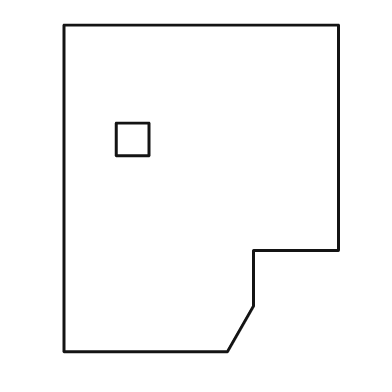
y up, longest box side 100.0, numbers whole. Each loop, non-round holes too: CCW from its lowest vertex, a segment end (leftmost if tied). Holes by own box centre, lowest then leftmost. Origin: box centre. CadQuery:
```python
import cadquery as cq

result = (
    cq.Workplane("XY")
    .moveTo(-42.0, -50.0)
    .lineTo(8.0, -50.0)
    .lineTo(16.0, -36.0)
    .lineTo(16.0, -19.0)
    .lineTo(42.0, -19.0)
    .lineTo(42.0, 50.0)
    .lineTo(-42.0, 50.0)
    .close()
    .moveTo(-26.0, 10.0)
    .lineTo(-16.0, 10.0)
    .lineTo(-16.0, 20.0)
    .lineTo(-26.0, 20.0)
    .close()
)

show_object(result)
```